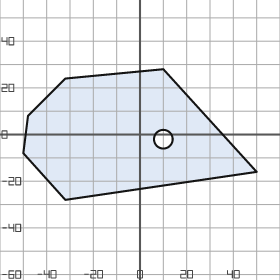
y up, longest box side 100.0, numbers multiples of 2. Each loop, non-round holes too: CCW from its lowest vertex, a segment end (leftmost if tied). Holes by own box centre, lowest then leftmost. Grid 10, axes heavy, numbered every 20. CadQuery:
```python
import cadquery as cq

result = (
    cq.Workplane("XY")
    .moveTo(-32.0, -28.0)
    .lineTo(50.0, -16.0)
    .lineTo(10.0, 28.0)
    .lineTo(-32.0, 24.0)
    .lineTo(-48.0, 8.0)
    .lineTo(-50.0, -8.0)
    .close()
    .moveTo(10.0, -2.0)
    .circle(4.0)
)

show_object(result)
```